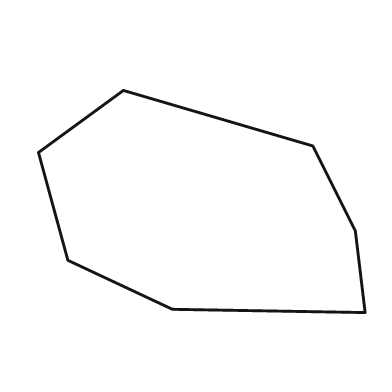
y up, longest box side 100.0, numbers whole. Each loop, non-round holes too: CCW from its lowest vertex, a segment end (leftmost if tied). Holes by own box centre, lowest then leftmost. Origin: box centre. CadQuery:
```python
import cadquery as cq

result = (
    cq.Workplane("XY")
    .moveTo(50.0, -34.0)
    .lineTo(47.0, -9.0)
    .lineTo(34.0, 17.0)
    .lineTo(-24.0, 34.0)
    .lineTo(-50.0, 15.0)
    .lineTo(-41.0, -18.0)
    .lineTo(-9.0, -33.0)
    .close()
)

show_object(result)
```